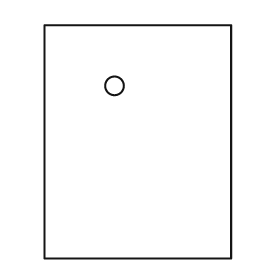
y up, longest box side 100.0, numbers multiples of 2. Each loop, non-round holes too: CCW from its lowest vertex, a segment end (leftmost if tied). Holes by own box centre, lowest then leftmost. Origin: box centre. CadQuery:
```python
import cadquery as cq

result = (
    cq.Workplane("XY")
    .moveTo(-40.0, -50.0)
    .lineTo(40.0, -50.0)
    .lineTo(40.0, 50.0)
    .lineTo(-40.0, 50.0)
    .close()
    .moveTo(-10.0, 24.0)
    .circle(4.0)
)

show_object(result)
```